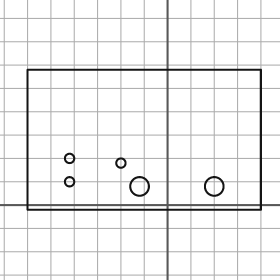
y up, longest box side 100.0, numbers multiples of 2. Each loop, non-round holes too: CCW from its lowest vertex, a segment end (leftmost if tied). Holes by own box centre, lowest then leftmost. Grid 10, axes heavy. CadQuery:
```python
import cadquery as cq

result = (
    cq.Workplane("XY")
    .moveTo(-60.0, -2.0)
    .lineTo(40.0, -2.0)
    .lineTo(40.0, 58.0)
    .lineTo(-60.0, 58.0)
    .close()
    .moveTo(-12.0, 8.0)
    .circle(4.0)
    .moveTo(20.0, 8.0)
    .circle(4.0)
    .moveTo(-42.0, 10.0)
    .circle(2.0)
    .moveTo(-20.0, 18.0)
    .circle(2.0)
    .moveTo(-42.0, 20.0)
    .circle(2.0)
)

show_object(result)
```